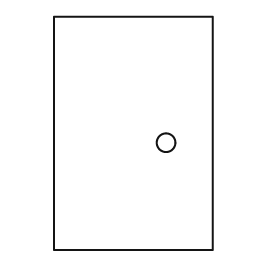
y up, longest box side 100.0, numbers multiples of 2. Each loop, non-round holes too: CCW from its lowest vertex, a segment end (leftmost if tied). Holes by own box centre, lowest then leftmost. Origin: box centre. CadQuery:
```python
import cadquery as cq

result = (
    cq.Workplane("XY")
    .moveTo(-34.0, -50.0)
    .lineTo(34.0, -50.0)
    .lineTo(34.0, 50.0)
    .lineTo(-34.0, 50.0)
    .close()
    .moveTo(14.0, -4.0)
    .circle(4.0)
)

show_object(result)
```